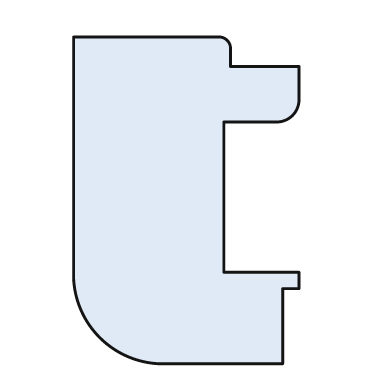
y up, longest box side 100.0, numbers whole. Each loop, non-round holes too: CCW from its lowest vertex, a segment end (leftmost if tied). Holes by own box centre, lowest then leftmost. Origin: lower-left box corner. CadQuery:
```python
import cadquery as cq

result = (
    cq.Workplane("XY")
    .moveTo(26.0, 0.0)
    .lineTo(64.0, 0.0)
    .lineTo(64.0, 23.0)
    .lineTo(69.0, 23.0)
    .lineTo(69.0, 28.0)
    .lineTo(46.0, 28.0)
    .lineTo(46.0, 74.0)
    .lineTo(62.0, 74.0)
    .threePointArc((67.0, 76.0), (69.0, 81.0))
    .lineTo(69.0, 91.0)
    .lineTo(48.0, 91.0)
    .lineTo(48.0, 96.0)
    .threePointArc((47.0, 99.0), (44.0, 100.0))
    .lineTo(0.0, 100.0)
    .lineTo(0.0, 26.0)
    .threePointArc((8.0, 8.0), (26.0, 0.0))
    .close()
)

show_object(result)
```